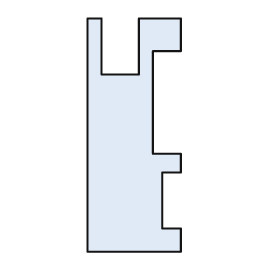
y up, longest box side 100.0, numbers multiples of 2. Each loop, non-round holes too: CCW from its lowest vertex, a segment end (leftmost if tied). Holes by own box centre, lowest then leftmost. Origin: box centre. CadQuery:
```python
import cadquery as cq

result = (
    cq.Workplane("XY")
    .moveTo(-20.0, -50.0)
    .lineTo(20.0, -50.0)
    .lineTo(20.0, -40.0)
    .lineTo(12.0, -40.0)
    .lineTo(12.0, -16.0)
    .lineTo(20.0, -16.0)
    .lineTo(20.0, -8.0)
    .lineTo(8.0, -8.0)
    .lineTo(8.0, 36.0)
    .lineTo(20.0, 36.0)
    .lineTo(20.0, 50.0)
    .lineTo(2.0, 50.0)
    .lineTo(2.0, 26.0)
    .lineTo(-14.0, 26.0)
    .lineTo(-14.0, 50.0)
    .lineTo(-20.0, 50.0)
    .close()
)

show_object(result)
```